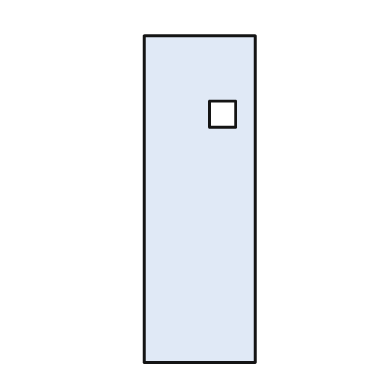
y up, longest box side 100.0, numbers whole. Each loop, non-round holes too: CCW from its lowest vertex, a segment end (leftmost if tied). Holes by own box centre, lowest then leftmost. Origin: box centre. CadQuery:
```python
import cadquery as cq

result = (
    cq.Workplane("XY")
    .moveTo(-17.0, -50.0)
    .lineTo(17.0, -50.0)
    .lineTo(17.0, 50.0)
    .lineTo(-17.0, 50.0)
    .close()
    .moveTo(3.0, 22.0)
    .lineTo(11.0, 22.0)
    .lineTo(11.0, 30.0)
    .lineTo(3.0, 30.0)
    .close()
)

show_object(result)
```